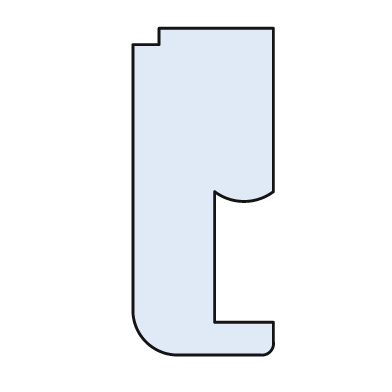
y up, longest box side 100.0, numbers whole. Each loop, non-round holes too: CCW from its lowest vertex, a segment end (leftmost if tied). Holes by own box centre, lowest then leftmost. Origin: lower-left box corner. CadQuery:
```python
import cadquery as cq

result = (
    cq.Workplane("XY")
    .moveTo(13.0, 0.0)
    .lineTo(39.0, 0.0)
    .threePointArc((42.0, 1.0), (43.0, 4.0))
    .lineTo(43.0, 10.0)
    .lineTo(25.0, 10.0)
    .lineTo(25.0, 50.0)
    .threePointArc((34.0, 47.0), (43.0, 50.0))
    .lineTo(43.0, 100.0)
    .lineTo(8.0, 100.0)
    .lineTo(8.0, 95.0)
    .lineTo(0.0, 95.0)
    .lineTo(0.0, 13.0)
    .threePointArc((4.0, 4.0), (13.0, 0.0))
    .close()
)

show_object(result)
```